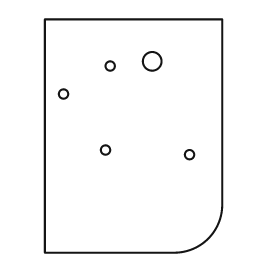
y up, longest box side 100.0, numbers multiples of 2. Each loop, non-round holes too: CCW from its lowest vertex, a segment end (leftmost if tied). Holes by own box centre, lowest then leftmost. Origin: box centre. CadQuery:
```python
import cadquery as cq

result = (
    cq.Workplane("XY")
    .moveTo(-38.0, -50.0)
    .lineTo(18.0, -50.0)
    .threePointArc((32.0, -44.0), (38.0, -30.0))
    .lineTo(38.0, 50.0)
    .lineTo(-38.0, 50.0)
    .close()
    .moveTo(24.0, -8.0)
    .circle(2.0)
    .moveTo(-12.0, -6.0)
    .circle(2.0)
    .moveTo(-30.0, 18.0)
    .circle(2.0)
    .moveTo(-10.0, 30.0)
    .circle(2.0)
    .moveTo(8.0, 32.0)
    .circle(4.0)
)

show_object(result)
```